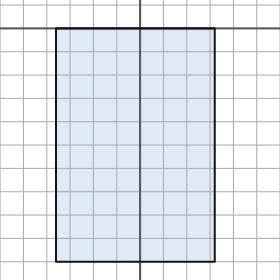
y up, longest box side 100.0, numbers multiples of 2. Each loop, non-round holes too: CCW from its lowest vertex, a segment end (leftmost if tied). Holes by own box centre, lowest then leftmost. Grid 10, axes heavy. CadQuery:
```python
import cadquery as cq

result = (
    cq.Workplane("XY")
    .moveTo(-36.0, -100.0)
    .lineTo(32.0, -100.0)
    .lineTo(32.0, 0.0)
    .lineTo(-36.0, 0.0)
    .close()
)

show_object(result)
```